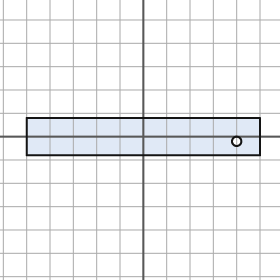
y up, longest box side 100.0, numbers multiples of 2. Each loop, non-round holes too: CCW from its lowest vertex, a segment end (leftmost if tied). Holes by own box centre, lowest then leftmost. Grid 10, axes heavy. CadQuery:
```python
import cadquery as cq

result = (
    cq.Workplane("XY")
    .moveTo(-50.0, -8.0)
    .lineTo(50.0, -8.0)
    .lineTo(50.0, 8.0)
    .lineTo(-50.0, 8.0)
    .close()
    .moveTo(40.0, -2.0)
    .circle(2.0)
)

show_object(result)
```